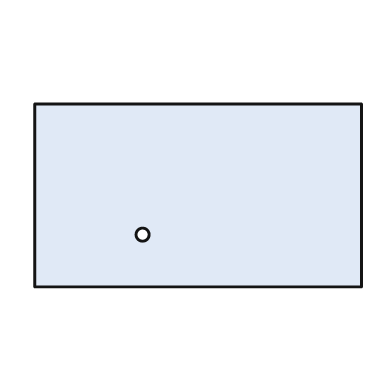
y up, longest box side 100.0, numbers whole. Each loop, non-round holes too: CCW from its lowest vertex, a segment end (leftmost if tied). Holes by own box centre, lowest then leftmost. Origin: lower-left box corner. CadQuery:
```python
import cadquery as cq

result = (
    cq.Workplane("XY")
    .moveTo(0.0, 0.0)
    .lineTo(100.0, 0.0)
    .lineTo(100.0, 56.0)
    .lineTo(0.0, 56.0)
    .close()
    .moveTo(33.0, 16.0)
    .circle(2.0)
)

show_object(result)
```